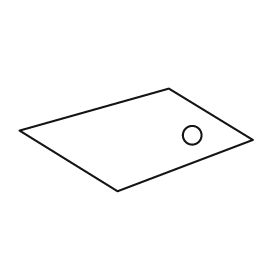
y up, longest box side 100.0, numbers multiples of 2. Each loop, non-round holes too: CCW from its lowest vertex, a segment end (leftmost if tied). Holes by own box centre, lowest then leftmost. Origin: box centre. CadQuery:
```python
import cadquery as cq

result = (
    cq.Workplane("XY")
    .moveTo(-8.0, -22.0)
    .lineTo(50.0, 0.0)
    .lineTo(14.0, 22.0)
    .lineTo(-50.0, 4.0)
    .close()
    .moveTo(24.0, 2.0)
    .circle(4.0)
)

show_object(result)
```